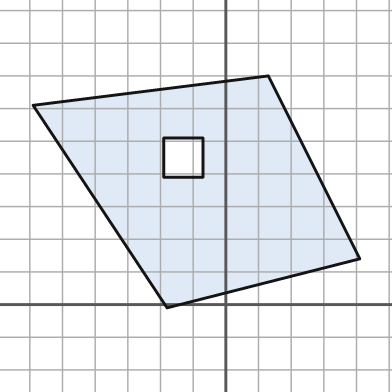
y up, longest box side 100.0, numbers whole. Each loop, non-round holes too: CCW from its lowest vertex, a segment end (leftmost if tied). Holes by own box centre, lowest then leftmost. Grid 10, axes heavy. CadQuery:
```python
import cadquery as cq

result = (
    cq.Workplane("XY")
    .moveTo(-18.0, -1.0)
    .lineTo(41.0, 14.0)
    .lineTo(13.0, 70.0)
    .lineTo(-59.0, 61.0)
    .close()
    .moveTo(-19.0, 39.0)
    .lineTo(-7.0, 39.0)
    .lineTo(-7.0, 51.0)
    .lineTo(-19.0, 51.0)
    .close()
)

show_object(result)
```